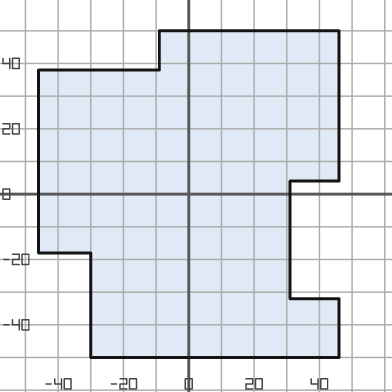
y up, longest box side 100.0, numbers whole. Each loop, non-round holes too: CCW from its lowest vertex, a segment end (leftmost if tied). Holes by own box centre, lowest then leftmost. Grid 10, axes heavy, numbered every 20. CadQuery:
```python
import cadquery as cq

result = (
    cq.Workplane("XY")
    .moveTo(-30.0, -50.0)
    .lineTo(46.0, -50.0)
    .lineTo(46.0, -32.0)
    .lineTo(31.0, -32.0)
    .lineTo(31.0, 4.0)
    .lineTo(46.0, 4.0)
    .lineTo(46.0, 50.0)
    .lineTo(-9.0, 50.0)
    .lineTo(-9.0, 38.0)
    .lineTo(-46.0, 38.0)
    .lineTo(-46.0, -18.0)
    .lineTo(-30.0, -18.0)
    .close()
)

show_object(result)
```